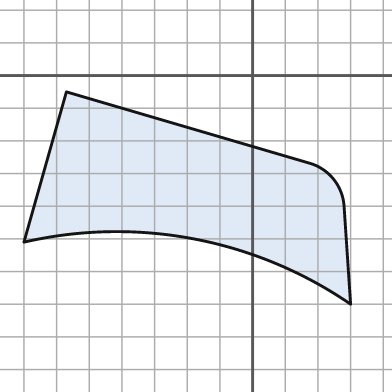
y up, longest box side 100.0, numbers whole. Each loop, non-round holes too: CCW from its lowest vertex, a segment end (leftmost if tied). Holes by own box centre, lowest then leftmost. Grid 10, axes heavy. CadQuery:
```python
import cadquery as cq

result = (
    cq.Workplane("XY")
    .moveTo(30.0, -70.0)
    .lineTo(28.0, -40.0)
    .threePointArc((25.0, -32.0), (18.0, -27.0))
    .lineTo(-57.0, -5.0)
    .lineTo(-70.0, -51.0)
    .threePointArc((-18.0, -50.0), (30.0, -70.0))
    .close()
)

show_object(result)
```